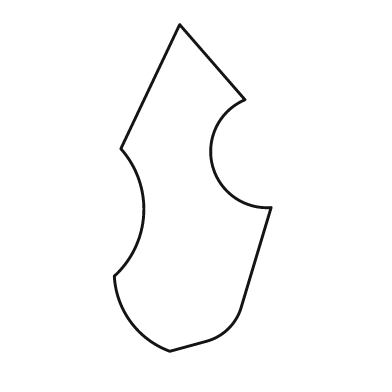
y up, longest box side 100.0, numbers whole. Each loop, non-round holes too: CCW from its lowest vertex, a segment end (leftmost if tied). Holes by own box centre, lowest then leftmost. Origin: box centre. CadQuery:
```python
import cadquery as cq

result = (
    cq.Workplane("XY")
    .moveTo(-7.0, -50.0)
    .lineTo(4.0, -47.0)
    .threePointArc((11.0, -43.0), (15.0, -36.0))
    .lineTo(24.0, -6.0)
    .threePointArc((6.0, 7.0), (16.0, 27.0))
    .lineTo(-4.0, 50.0)
    .lineTo(-22.0, 12.0)
    .threePointArc((-15.0, -8.0), (-24.0, -27.0))
    .threePointArc((-19.0, -41.0), (-7.0, -50.0))
    .close()
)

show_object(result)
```